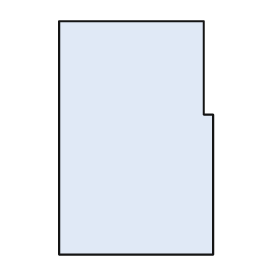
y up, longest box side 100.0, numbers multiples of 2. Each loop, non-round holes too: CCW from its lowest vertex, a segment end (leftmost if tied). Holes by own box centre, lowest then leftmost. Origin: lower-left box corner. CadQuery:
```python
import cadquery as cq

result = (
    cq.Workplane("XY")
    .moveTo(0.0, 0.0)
    .lineTo(66.0, 0.0)
    .lineTo(66.0, 60.0)
    .lineTo(62.0, 60.0)
    .lineTo(62.0, 100.0)
    .lineTo(0.0, 100.0)
    .close()
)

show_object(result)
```